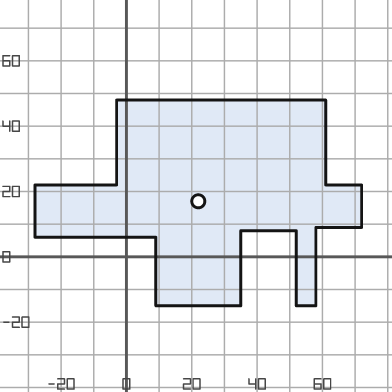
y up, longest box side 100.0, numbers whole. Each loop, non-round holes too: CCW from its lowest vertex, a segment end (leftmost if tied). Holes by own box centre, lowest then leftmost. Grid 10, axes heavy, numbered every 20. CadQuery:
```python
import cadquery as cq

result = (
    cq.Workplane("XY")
    .moveTo(9.0, -15.0)
    .lineTo(35.0, -15.0)
    .lineTo(35.0, 8.0)
    .lineTo(52.0, 8.0)
    .lineTo(52.0, -15.0)
    .lineTo(58.0, -15.0)
    .lineTo(58.0, 9.0)
    .lineTo(72.0, 9.0)
    .lineTo(72.0, 22.0)
    .lineTo(61.0, 22.0)
    .lineTo(61.0, 48.0)
    .lineTo(-3.0, 48.0)
    .lineTo(-3.0, 22.0)
    .lineTo(-28.0, 22.0)
    .lineTo(-28.0, 6.0)
    .lineTo(9.0, 6.0)
    .close()
    .moveTo(22.0, 17.0)
    .circle(2.0)
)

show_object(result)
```